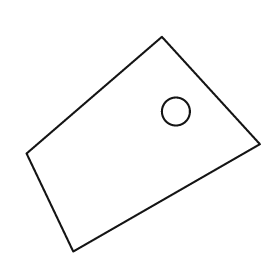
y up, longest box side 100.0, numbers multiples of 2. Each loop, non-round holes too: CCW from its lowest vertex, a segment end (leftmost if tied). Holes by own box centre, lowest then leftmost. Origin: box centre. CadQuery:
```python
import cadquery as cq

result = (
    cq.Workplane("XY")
    .moveTo(-30.0, -46.0)
    .lineTo(50.0, 0.0)
    .lineTo(8.0, 46.0)
    .lineTo(-50.0, -4.0)
    .close()
    .moveTo(14.0, 14.0)
    .circle(6.0)
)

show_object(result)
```